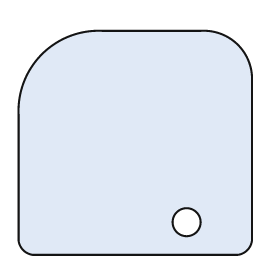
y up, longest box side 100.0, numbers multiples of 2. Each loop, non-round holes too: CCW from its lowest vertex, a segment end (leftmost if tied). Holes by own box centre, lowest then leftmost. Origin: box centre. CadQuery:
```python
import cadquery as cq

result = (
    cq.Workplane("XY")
    .moveTo(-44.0, -48.0)
    .lineTo(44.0, -48.0)
    .threePointArc((48.0, -46.0), (50.0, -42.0))
    .lineTo(50.0, 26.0)
    .threePointArc((44.0, 42.0), (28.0, 48.0))
    .lineTo(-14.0, 48.0)
    .threePointArc((-40.0, 38.0), (-50.0, 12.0))
    .lineTo(-50.0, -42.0)
    .threePointArc((-48.0, -46.0), (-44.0, -48.0))
    .close()
    .moveTo(22.0, -34.0)
    .circle(6.0)
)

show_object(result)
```